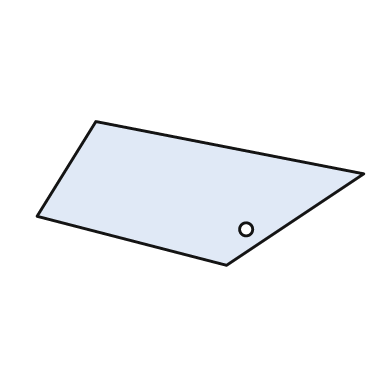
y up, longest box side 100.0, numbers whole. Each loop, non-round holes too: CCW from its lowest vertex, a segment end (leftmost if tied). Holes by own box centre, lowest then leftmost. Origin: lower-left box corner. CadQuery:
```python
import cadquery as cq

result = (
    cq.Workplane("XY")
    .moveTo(58.0, 0.0)
    .lineTo(100.0, 28.0)
    .lineTo(18.0, 44.0)
    .lineTo(0.0, 15.0)
    .close()
    .moveTo(64.0, 11.0)
    .circle(2.0)
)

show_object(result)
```